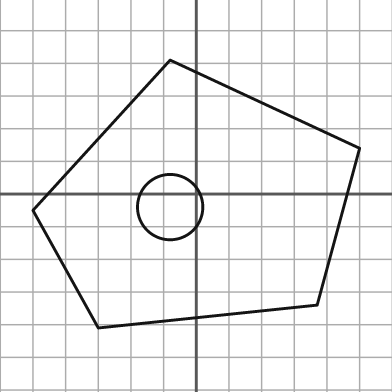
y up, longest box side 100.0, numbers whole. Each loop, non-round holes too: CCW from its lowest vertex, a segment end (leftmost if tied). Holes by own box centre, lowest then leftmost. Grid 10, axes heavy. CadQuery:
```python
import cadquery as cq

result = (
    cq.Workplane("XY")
    .moveTo(-30.0, -41.0)
    .lineTo(37.0, -34.0)
    .lineTo(50.0, 14.0)
    .lineTo(-8.0, 41.0)
    .lineTo(-50.0, -5.0)
    .close()
    .moveTo(-8.0, -4.0)
    .circle(10.0)
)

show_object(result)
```